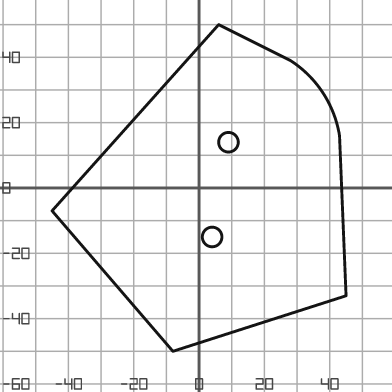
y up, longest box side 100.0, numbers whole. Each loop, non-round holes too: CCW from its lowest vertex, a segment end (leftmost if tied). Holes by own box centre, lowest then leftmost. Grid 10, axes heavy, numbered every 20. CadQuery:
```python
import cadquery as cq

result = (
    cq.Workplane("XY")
    .moveTo(-8.0, -50.0)
    .lineTo(45.0, -33.0)
    .lineTo(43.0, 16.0)
    .threePointArc((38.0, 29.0), (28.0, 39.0))
    .lineTo(6.0, 50.0)
    .lineTo(-45.0, -7.0)
    .close()
    .moveTo(4.0, -15.0)
    .circle(3.0)
    .moveTo(9.0, 14.0)
    .circle(3.0)
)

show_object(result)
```